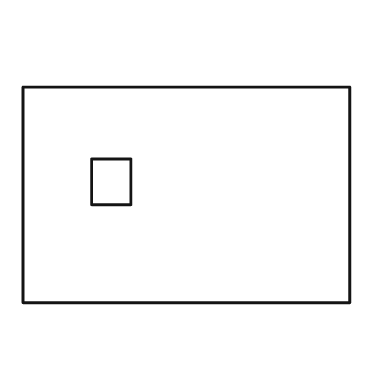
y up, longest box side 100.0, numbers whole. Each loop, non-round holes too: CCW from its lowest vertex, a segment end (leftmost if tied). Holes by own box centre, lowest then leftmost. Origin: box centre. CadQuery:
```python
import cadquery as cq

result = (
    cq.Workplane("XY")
    .moveTo(-50.0, -33.0)
    .lineTo(50.0, -33.0)
    .lineTo(50.0, 33.0)
    .lineTo(-50.0, 33.0)
    .close()
    .moveTo(-29.0, -3.0)
    .lineTo(-17.0, -3.0)
    .lineTo(-17.0, 11.0)
    .lineTo(-29.0, 11.0)
    .close()
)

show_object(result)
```